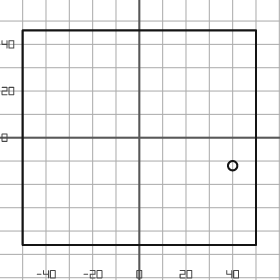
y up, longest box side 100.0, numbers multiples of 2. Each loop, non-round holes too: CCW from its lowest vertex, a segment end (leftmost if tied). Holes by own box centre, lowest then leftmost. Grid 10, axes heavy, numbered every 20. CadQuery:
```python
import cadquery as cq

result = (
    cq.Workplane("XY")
    .moveTo(-50.0, -46.0)
    .lineTo(50.0, -46.0)
    .lineTo(50.0, 46.0)
    .lineTo(-50.0, 46.0)
    .close()
    .moveTo(40.0, -12.0)
    .circle(2.0)
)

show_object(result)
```